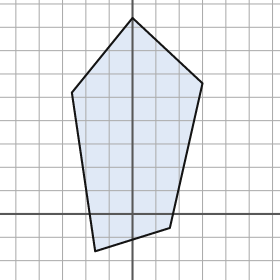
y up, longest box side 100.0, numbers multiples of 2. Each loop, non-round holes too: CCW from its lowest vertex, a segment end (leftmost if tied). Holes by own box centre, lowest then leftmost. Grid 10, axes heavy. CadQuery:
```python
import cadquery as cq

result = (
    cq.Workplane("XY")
    .moveTo(-16.0, -16.0)
    .lineTo(16.0, -6.0)
    .lineTo(30.0, 56.0)
    .lineTo(0.0, 84.0)
    .lineTo(-26.0, 52.0)
    .close()
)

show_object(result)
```